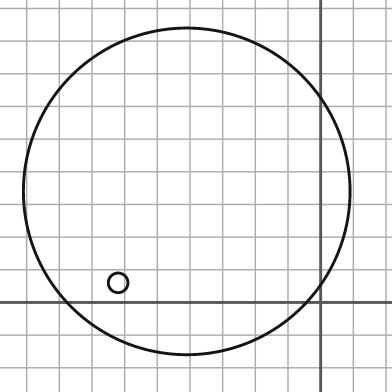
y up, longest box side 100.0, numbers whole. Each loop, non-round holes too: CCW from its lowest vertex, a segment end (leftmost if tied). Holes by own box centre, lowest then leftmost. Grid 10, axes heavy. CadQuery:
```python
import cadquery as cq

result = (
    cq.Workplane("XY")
    .moveTo(-41.0, 34.0)
    .circle(50.0)
    .moveTo(-62.0, 6.0)
    .circle(3.0)
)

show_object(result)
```